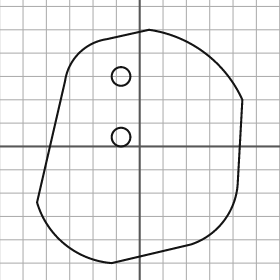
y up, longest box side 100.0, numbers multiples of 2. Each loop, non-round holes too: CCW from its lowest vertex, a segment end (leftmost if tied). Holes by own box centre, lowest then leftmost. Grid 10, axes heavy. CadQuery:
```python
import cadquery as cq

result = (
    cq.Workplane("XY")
    .moveTo(-12.0, -50.0)
    .lineTo(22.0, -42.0)
    .threePointArc((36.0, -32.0), (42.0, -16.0))
    .lineTo(44.0, 20.0)
    .threePointArc((28.0, 40.0), (4.0, 50.0))
    .lineTo(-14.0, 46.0)
    .threePointArc((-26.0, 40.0), (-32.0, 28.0))
    .lineTo(-44.0, -24.0)
    .threePointArc((-32.0, -42.0), (-12.0, -50.0))
    .close()
    .moveTo(-8.0, 4.0)
    .circle(4.0)
    .moveTo(-8.0, 30.0)
    .circle(4.0)
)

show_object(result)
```